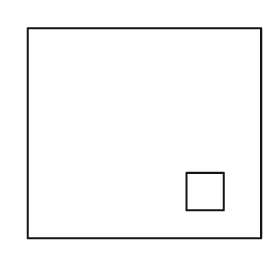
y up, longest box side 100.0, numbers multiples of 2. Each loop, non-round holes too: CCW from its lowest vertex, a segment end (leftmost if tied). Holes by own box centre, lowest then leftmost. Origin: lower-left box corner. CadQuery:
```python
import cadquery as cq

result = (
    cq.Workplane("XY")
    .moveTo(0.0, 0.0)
    .lineTo(100.0, 0.0)
    .lineTo(100.0, 90.0)
    .lineTo(0.0, 90.0)
    .close()
    .moveTo(68.0, 12.0)
    .lineTo(84.0, 12.0)
    .lineTo(84.0, 28.0)
    .lineTo(68.0, 28.0)
    .close()
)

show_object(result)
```